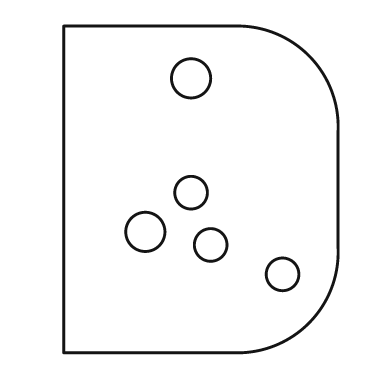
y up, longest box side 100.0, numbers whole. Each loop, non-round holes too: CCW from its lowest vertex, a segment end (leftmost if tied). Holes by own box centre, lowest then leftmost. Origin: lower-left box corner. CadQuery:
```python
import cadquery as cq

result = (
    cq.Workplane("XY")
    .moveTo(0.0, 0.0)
    .lineTo(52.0, 0.0)
    .threePointArc((75.0, 9.0), (84.0, 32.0))
    .lineTo(84.0, 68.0)
    .threePointArc((75.0, 91.0), (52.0, 100.0))
    .lineTo(0.0, 100.0)
    .close()
    .moveTo(67.0, 24.0)
    .circle(5.0)
    .moveTo(45.0, 33.0)
    .circle(5.0)
    .moveTo(25.0, 37.0)
    .circle(6.0)
    .moveTo(39.0, 49.0)
    .circle(5.0)
    .moveTo(39.0, 84.0)
    .circle(6.0)
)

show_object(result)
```